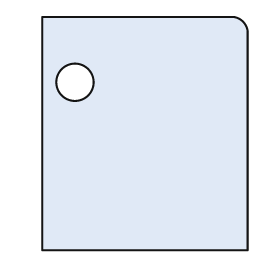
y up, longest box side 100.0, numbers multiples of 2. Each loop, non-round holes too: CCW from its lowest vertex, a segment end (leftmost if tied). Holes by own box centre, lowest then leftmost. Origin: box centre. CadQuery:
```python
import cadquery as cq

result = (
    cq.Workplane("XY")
    .moveTo(-44.0, -50.0)
    .lineTo(44.0, -50.0)
    .lineTo(44.0, 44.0)
    .threePointArc((42.0, 48.0), (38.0, 50.0))
    .lineTo(-44.0, 50.0)
    .close()
    .moveTo(-30.0, 22.0)
    .circle(8.0)
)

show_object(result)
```